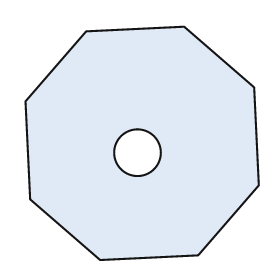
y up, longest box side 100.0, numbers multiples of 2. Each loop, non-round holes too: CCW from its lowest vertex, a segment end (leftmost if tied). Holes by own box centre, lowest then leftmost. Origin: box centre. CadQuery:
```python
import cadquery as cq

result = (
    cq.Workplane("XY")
    .moveTo(-18.0, -50.0)
    .lineTo(24.0, -48.0)
    .lineTo(50.0, -18.0)
    .lineTo(48.0, 24.0)
    .lineTo(18.0, 50.0)
    .lineTo(-24.0, 48.0)
    .lineTo(-50.0, 18.0)
    .lineTo(-48.0, -24.0)
    .close()
    .moveTo(-2.0, -4.0)
    .circle(10.0)
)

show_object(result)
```